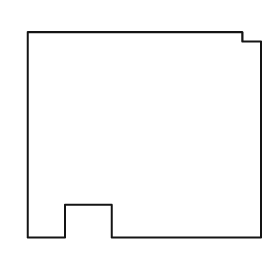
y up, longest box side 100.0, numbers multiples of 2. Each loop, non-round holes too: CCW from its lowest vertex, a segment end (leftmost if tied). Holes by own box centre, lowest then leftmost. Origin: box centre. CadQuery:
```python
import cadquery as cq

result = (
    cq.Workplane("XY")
    .moveTo(-50.0, -44.0)
    .lineTo(-34.0, -44.0)
    .lineTo(-34.0, -30.0)
    .lineTo(-14.0, -30.0)
    .lineTo(-14.0, -44.0)
    .lineTo(50.0, -44.0)
    .lineTo(50.0, 40.0)
    .lineTo(42.0, 40.0)
    .lineTo(42.0, 44.0)
    .lineTo(-50.0, 44.0)
    .close()
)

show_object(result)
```